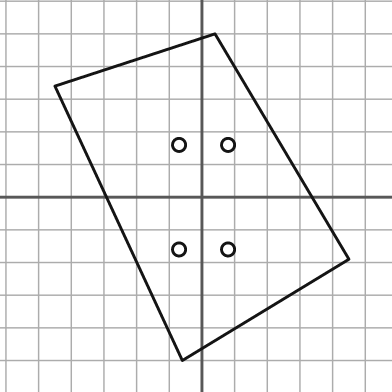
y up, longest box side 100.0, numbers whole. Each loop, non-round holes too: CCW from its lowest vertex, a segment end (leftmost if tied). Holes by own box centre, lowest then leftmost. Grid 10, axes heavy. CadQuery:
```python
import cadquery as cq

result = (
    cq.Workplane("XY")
    .moveTo(-6.0, -50.0)
    .lineTo(45.0, -19.0)
    .lineTo(4.0, 50.0)
    .lineTo(-45.0, 34.0)
    .close()
    .moveTo(-7.0, -16.0)
    .circle(2.0)
    .moveTo(8.0, -16.0)
    .circle(2.0)
    .moveTo(-7.0, 16.0)
    .circle(2.0)
    .moveTo(8.0, 16.0)
    .circle(2.0)
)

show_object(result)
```